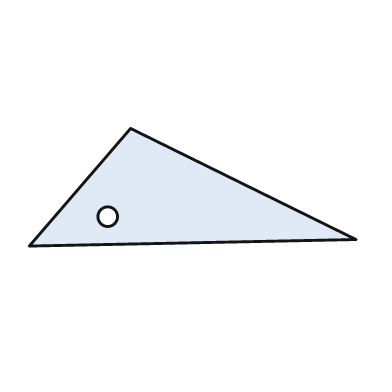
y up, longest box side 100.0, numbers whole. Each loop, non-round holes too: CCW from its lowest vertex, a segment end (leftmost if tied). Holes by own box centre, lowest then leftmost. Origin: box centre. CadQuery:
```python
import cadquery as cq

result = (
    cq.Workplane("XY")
    .moveTo(-50.0, -18.0)
    .lineTo(50.0, -16.0)
    .lineTo(-19.0, 18.0)
    .close()
    .moveTo(-26.0, -9.0)
    .circle(3.0)
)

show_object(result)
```